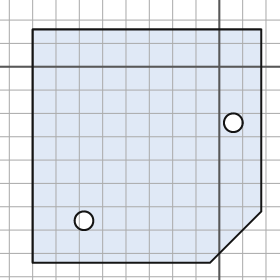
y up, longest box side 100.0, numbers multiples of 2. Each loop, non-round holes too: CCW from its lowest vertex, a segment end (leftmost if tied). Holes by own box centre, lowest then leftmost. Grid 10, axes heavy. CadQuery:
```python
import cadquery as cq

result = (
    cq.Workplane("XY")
    .moveTo(-80.0, -84.0)
    .lineTo(-4.0, -84.0)
    .lineTo(18.0, -62.0)
    .lineTo(18.0, 16.0)
    .lineTo(-80.0, 16.0)
    .close()
    .moveTo(-58.0, -66.0)
    .circle(4.0)
    .moveTo(6.0, -24.0)
    .circle(4.0)
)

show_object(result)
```